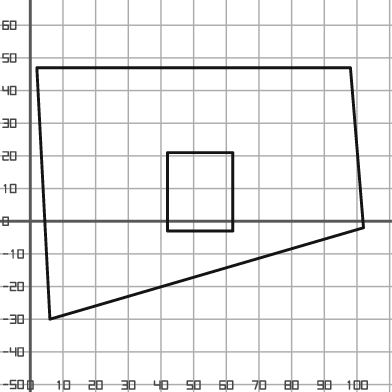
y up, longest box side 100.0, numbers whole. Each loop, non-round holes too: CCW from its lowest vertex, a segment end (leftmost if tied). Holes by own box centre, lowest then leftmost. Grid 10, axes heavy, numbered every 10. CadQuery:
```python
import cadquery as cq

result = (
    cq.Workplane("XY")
    .moveTo(6.0, -30.0)
    .lineTo(102.0, -2.0)
    .lineTo(98.0, 47.0)
    .lineTo(2.0, 47.0)
    .close()
    .moveTo(42.0, -3.0)
    .lineTo(62.0, -3.0)
    .lineTo(62.0, 21.0)
    .lineTo(42.0, 21.0)
    .close()
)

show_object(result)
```